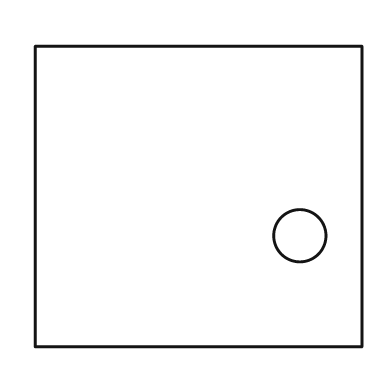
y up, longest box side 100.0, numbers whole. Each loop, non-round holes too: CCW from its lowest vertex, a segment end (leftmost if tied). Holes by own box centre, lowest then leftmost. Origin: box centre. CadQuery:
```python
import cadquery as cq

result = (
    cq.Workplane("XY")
    .moveTo(-50.0, -46.0)
    .lineTo(50.0, -46.0)
    .lineTo(50.0, 46.0)
    .lineTo(-50.0, 46.0)
    .close()
    .moveTo(31.0, -12.0)
    .circle(8.0)
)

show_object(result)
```